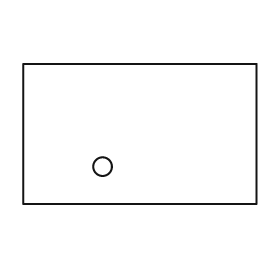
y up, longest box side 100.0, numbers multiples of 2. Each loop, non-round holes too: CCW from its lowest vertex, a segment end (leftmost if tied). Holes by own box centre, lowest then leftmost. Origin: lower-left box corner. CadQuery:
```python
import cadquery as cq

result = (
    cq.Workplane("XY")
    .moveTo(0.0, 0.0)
    .lineTo(100.0, 0.0)
    .lineTo(100.0, 60.0)
    .lineTo(0.0, 60.0)
    .close()
    .moveTo(34.0, 16.0)
    .circle(4.0)
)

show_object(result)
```